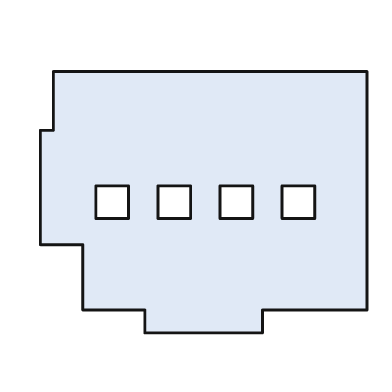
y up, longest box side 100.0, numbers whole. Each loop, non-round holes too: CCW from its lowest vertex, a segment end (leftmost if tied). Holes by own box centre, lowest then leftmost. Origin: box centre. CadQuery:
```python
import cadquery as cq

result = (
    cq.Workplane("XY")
    .moveTo(-18.0, -40.0)
    .lineTo(18.0, -40.0)
    .lineTo(18.0, -33.0)
    .lineTo(50.0, -33.0)
    .lineTo(50.0, 40.0)
    .lineTo(-46.0, 40.0)
    .lineTo(-46.0, 22.0)
    .lineTo(-50.0, 22.0)
    .lineTo(-50.0, -13.0)
    .lineTo(-37.0, -13.0)
    .lineTo(-37.0, -33.0)
    .lineTo(-18.0, -33.0)
    .close()
    .moveTo(-33.0, -5.0)
    .lineTo(-23.0, -5.0)
    .lineTo(-23.0, 5.0)
    .lineTo(-33.0, 5.0)
    .close()
    .moveTo(-14.0, -5.0)
    .lineTo(-4.0, -5.0)
    .lineTo(-4.0, 5.0)
    .lineTo(-14.0, 5.0)
    .close()
    .moveTo(5.0, -5.0)
    .lineTo(15.0, -5.0)
    .lineTo(15.0, 5.0)
    .lineTo(5.0, 5.0)
    .close()
    .moveTo(24.0, -5.0)
    .lineTo(34.0, -5.0)
    .lineTo(34.0, 5.0)
    .lineTo(24.0, 5.0)
    .close()
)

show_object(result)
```